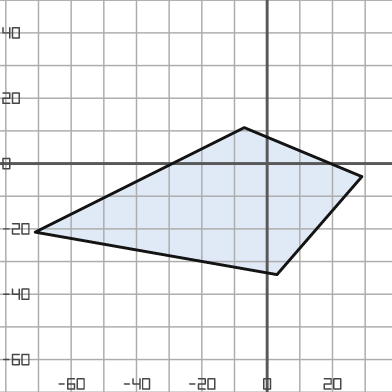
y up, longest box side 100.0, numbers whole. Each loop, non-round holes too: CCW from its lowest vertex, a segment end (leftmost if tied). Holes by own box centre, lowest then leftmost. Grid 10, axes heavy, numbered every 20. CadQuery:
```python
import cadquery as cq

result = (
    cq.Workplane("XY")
    .moveTo(3.0, -34.0)
    .lineTo(29.0, -4.0)
    .lineTo(-7.0, 11.0)
    .lineTo(-71.0, -21.0)
    .close()
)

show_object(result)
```